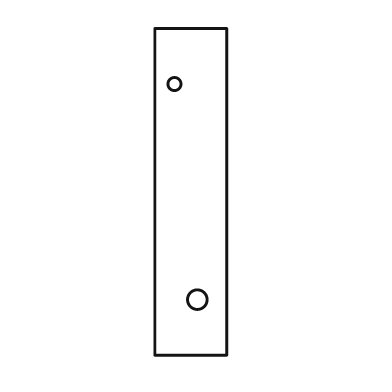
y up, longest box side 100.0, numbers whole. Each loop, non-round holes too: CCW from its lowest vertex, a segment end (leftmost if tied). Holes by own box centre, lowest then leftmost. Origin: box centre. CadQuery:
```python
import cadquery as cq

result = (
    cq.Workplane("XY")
    .moveTo(-11.0, -50.0)
    .lineTo(11.0, -50.0)
    .lineTo(11.0, 50.0)
    .lineTo(-11.0, 50.0)
    .close()
    .moveTo(2.0, -33.0)
    .circle(3.0)
    .moveTo(-5.0, 33.0)
    .circle(2.0)
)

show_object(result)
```